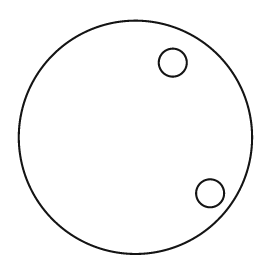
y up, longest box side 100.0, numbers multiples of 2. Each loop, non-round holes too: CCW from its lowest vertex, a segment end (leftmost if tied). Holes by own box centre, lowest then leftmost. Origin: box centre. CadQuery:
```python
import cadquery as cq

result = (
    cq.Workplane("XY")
    .moveTo(0.0, 0.0)
    .circle(50.0)
    .moveTo(32.0, -24.0)
    .circle(6.0)
    .moveTo(16.0, 32.0)
    .circle(6.0)
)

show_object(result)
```